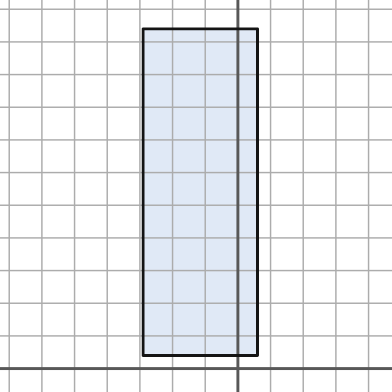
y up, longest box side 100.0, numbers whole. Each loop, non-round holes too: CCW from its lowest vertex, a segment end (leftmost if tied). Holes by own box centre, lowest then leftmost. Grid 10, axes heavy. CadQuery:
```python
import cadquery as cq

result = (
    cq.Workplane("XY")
    .moveTo(-29.0, 4.0)
    .lineTo(6.0, 4.0)
    .lineTo(6.0, 104.0)
    .lineTo(-29.0, 104.0)
    .close()
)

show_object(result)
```